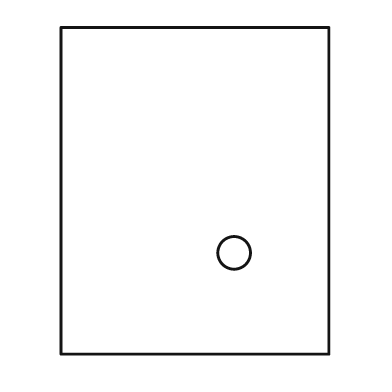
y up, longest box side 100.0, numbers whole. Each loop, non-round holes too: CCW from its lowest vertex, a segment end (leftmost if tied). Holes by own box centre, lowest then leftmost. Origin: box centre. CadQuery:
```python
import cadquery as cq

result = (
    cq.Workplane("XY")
    .moveTo(-41.0, -50.0)
    .lineTo(41.0, -50.0)
    .lineTo(41.0, 50.0)
    .lineTo(-41.0, 50.0)
    .close()
    .moveTo(12.0, -19.0)
    .circle(5.0)
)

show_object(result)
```